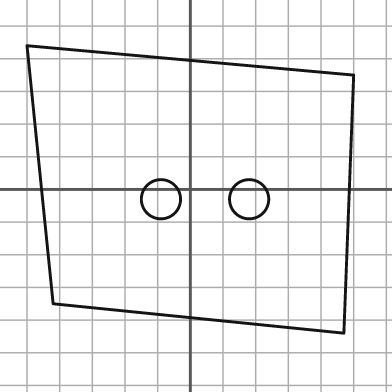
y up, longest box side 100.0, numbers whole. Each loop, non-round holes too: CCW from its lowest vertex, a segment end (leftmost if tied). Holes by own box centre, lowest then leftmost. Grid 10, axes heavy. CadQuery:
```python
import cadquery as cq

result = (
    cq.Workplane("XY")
    .moveTo(47.0, -44.0)
    .lineTo(50.0, 35.0)
    .lineTo(-50.0, 44.0)
    .lineTo(-42.0, -35.0)
    .close()
    .moveTo(-9.0, -3.0)
    .circle(6.0)
    .moveTo(18.0, -3.0)
    .circle(6.0)
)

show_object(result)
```